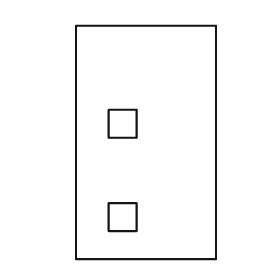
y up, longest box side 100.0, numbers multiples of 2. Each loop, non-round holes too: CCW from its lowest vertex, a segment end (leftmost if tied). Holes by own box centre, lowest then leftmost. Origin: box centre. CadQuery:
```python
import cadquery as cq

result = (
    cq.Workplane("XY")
    .moveTo(-30.0, -50.0)
    .lineTo(30.0, -50.0)
    .lineTo(30.0, 50.0)
    .lineTo(-30.0, 50.0)
    .close()
    .moveTo(-16.0, -38.0)
    .lineTo(-4.0, -38.0)
    .lineTo(-4.0, -26.0)
    .lineTo(-16.0, -26.0)
    .close()
    .moveTo(-16.0, 2.0)
    .lineTo(-4.0, 2.0)
    .lineTo(-4.0, 14.0)
    .lineTo(-16.0, 14.0)
    .close()
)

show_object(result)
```